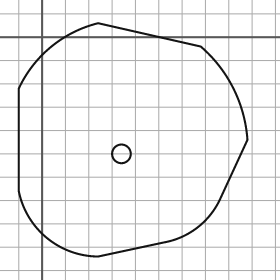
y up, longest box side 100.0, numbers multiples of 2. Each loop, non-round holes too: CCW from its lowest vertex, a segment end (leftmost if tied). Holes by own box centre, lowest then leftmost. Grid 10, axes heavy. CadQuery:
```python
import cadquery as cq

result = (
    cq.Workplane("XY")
    .moveTo(24.0, -94.0)
    .lineTo(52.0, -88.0)
    .threePointArc((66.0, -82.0), (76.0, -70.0))
    .lineTo(88.0, -44.0)
    .threePointArc((82.0, -22.0), (68.0, -4.0))
    .lineTo(24.0, 6.0)
    .threePointArc((4.0, -4.0), (-10.0, -22.0))
    .lineTo(-10.0, -66.0)
    .threePointArc((2.0, -86.0), (24.0, -94.0))
    .close()
    .moveTo(34.0, -50.0)
    .circle(4.0)
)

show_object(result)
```